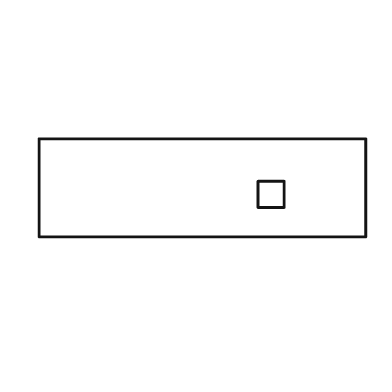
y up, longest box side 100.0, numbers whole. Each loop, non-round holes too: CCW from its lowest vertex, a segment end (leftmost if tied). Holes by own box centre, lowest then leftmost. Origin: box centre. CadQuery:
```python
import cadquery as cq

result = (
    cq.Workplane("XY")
    .moveTo(-50.0, -15.0)
    .lineTo(50.0, -15.0)
    .lineTo(50.0, 15.0)
    .lineTo(-50.0, 15.0)
    .close()
    .moveTo(17.0, -6.0)
    .lineTo(25.0, -6.0)
    .lineTo(25.0, 2.0)
    .lineTo(17.0, 2.0)
    .close()
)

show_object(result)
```